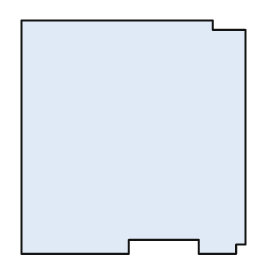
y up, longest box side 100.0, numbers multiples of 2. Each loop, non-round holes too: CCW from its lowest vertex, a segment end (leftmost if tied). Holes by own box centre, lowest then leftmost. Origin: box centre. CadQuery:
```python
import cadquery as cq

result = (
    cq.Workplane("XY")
    .moveTo(-48.0, -50.0)
    .lineTo(-2.0, -50.0)
    .lineTo(-2.0, -44.0)
    .lineTo(28.0, -44.0)
    .lineTo(28.0, -50.0)
    .lineTo(44.0, -50.0)
    .lineTo(44.0, -46.0)
    .lineTo(48.0, -46.0)
    .lineTo(48.0, 46.0)
    .lineTo(34.0, 46.0)
    .lineTo(34.0, 50.0)
    .lineTo(-48.0, 50.0)
    .close()
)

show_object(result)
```